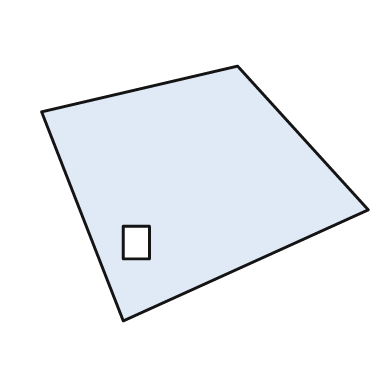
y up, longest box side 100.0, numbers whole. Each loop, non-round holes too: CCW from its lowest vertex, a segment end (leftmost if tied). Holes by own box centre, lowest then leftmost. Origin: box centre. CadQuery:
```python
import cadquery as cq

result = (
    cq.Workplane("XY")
    .moveTo(-25.0, -39.0)
    .lineTo(50.0, -5.0)
    .lineTo(10.0, 39.0)
    .lineTo(-50.0, 25.0)
    .close()
    .moveTo(-25.0, -20.0)
    .lineTo(-17.0, -20.0)
    .lineTo(-17.0, -10.0)
    .lineTo(-25.0, -10.0)
    .close()
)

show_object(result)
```